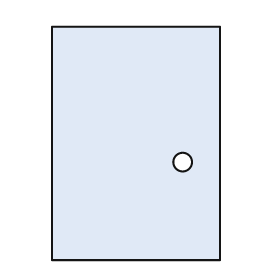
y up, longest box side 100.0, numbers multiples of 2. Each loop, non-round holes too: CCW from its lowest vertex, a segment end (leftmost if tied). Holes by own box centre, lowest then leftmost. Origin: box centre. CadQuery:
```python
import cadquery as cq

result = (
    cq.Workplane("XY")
    .moveTo(-36.0, -50.0)
    .lineTo(36.0, -50.0)
    .lineTo(36.0, 50.0)
    .lineTo(-36.0, 50.0)
    .close()
    .moveTo(20.0, -8.0)
    .circle(4.0)
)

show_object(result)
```